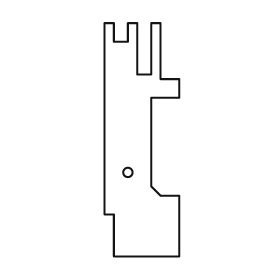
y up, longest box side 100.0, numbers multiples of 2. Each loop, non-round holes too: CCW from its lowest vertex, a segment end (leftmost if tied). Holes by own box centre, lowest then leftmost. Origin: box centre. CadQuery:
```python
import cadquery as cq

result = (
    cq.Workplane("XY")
    .moveTo(-12.0, -50.0)
    .lineTo(16.0, -50.0)
    .lineTo(16.0, -24.0)
    .lineTo(8.0, -24.0)
    .lineTo(4.0, -20.0)
    .lineTo(4.0, 18.0)
    .lineTo(16.0, 18.0)
    .lineTo(16.0, 26.0)
    .lineTo(8.0, 26.0)
    .lineTo(8.0, 50.0)
    .lineTo(4.0, 50.0)
    .lineTo(4.0, 28.0)
    .lineTo(-2.0, 28.0)
    .lineTo(-2.0, 50.0)
    .lineTo(-6.0, 50.0)
    .lineTo(-6.0, 42.0)
    .lineTo(-12.0, 42.0)
    .lineTo(-12.0, 50.0)
    .lineTo(-16.0, 50.0)
    .lineTo(-16.0, -32.0)
    .lineTo(-12.0, -32.0)
    .close()
    .moveTo(-6.0, -14.0)
    .circle(2.0)
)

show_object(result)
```